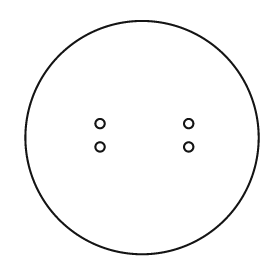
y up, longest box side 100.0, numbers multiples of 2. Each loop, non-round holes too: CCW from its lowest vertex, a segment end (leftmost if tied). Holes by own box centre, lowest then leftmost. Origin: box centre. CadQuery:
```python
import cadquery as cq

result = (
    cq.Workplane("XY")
    .moveTo(0.0, 0.0)
    .circle(50.0)
    .moveTo(-18.0, -4.0)
    .circle(2.0)
    .moveTo(20.0, -4.0)
    .circle(2.0)
    .moveTo(-18.0, 6.0)
    .circle(2.0)
    .moveTo(20.0, 6.0)
    .circle(2.0)
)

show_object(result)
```